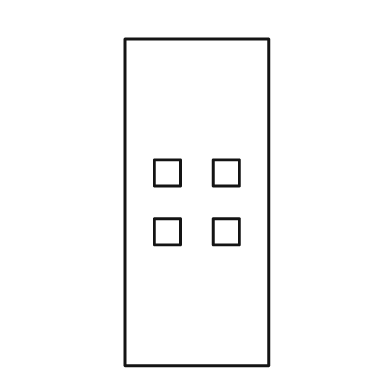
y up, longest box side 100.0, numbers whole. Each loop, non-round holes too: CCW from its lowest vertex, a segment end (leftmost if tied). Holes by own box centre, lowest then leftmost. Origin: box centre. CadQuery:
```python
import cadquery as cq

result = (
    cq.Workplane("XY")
    .moveTo(-22.0, -50.0)
    .lineTo(22.0, -50.0)
    .lineTo(22.0, 50.0)
    .lineTo(-22.0, 50.0)
    .close()
    .moveTo(-13.0, -13.0)
    .lineTo(-5.0, -13.0)
    .lineTo(-5.0, -5.0)
    .lineTo(-13.0, -5.0)
    .close()
    .moveTo(5.0, -13.0)
    .lineTo(13.0, -13.0)
    .lineTo(13.0, -5.0)
    .lineTo(5.0, -5.0)
    .close()
    .moveTo(-13.0, 5.0)
    .lineTo(-5.0, 5.0)
    .lineTo(-5.0, 13.0)
    .lineTo(-13.0, 13.0)
    .close()
    .moveTo(5.0, 5.0)
    .lineTo(13.0, 5.0)
    .lineTo(13.0, 13.0)
    .lineTo(5.0, 13.0)
    .close()
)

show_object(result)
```